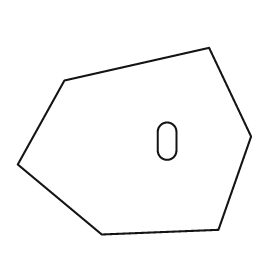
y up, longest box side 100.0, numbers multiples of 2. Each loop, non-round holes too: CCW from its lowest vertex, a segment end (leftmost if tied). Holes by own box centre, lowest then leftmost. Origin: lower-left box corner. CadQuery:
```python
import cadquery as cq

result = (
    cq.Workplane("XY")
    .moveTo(36.0, 0.0)
    .lineTo(86.0, 2.0)
    .lineTo(100.0, 42.0)
    .lineTo(82.0, 80.0)
    .lineTo(20.0, 66.0)
    .lineTo(0.0, 30.0)
    .close()
    .moveTo(60.0, 36.0)
    .threePointArc((64.0, 32.0), (68.0, 36.0))
    .lineTo(68.0, 44.0)
    .threePointArc((64.0, 48.0), (60.0, 44.0))
    .close()
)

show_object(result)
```